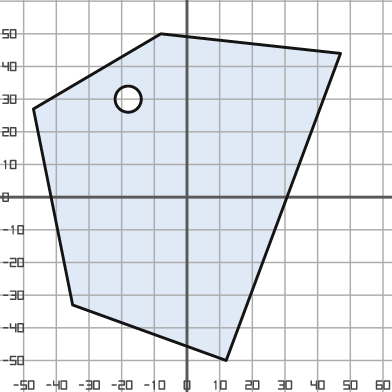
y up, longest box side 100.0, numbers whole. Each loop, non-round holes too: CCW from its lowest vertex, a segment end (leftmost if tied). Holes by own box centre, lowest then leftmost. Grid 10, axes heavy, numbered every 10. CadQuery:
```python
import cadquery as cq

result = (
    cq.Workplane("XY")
    .moveTo(12.0, -50.0)
    .lineTo(47.0, 44.0)
    .lineTo(-8.0, 50.0)
    .lineTo(-47.0, 27.0)
    .lineTo(-35.0, -33.0)
    .close()
    .moveTo(-18.0, 30.0)
    .circle(4.0)
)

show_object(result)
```